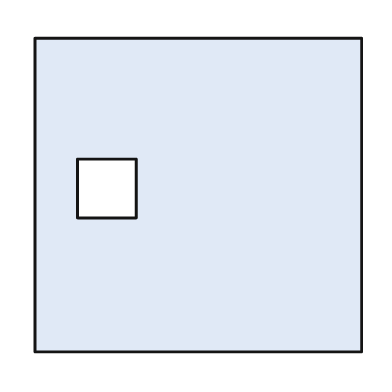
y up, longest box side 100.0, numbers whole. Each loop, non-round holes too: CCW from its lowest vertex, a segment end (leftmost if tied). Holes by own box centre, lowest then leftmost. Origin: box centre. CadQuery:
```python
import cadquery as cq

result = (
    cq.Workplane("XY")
    .moveTo(-50.0, -48.0)
    .lineTo(50.0, -48.0)
    .lineTo(50.0, 48.0)
    .lineTo(-50.0, 48.0)
    .close()
    .moveTo(-37.0, -7.0)
    .lineTo(-19.0, -7.0)
    .lineTo(-19.0, 11.0)
    .lineTo(-37.0, 11.0)
    .close()
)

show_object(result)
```